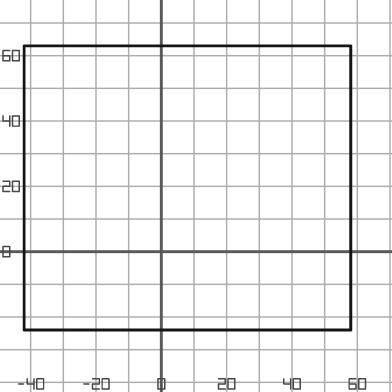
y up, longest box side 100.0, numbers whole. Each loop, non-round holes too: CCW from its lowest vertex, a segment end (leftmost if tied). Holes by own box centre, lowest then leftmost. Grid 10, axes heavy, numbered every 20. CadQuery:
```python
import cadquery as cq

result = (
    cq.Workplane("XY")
    .moveTo(-42.0, -24.0)
    .lineTo(58.0, -24.0)
    .lineTo(58.0, 63.0)
    .lineTo(-42.0, 63.0)
    .close()
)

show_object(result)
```